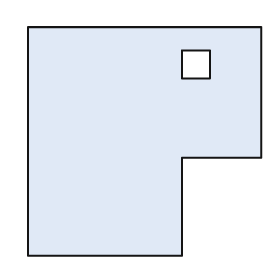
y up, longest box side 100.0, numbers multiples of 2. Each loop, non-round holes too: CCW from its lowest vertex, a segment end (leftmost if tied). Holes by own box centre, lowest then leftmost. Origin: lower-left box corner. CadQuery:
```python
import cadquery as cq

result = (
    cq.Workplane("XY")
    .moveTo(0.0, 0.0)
    .lineTo(66.0, 0.0)
    .lineTo(66.0, 42.0)
    .lineTo(100.0, 42.0)
    .lineTo(100.0, 98.0)
    .lineTo(0.0, 98.0)
    .close()
    .moveTo(66.0, 76.0)
    .lineTo(78.0, 76.0)
    .lineTo(78.0, 88.0)
    .lineTo(66.0, 88.0)
    .close()
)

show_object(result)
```